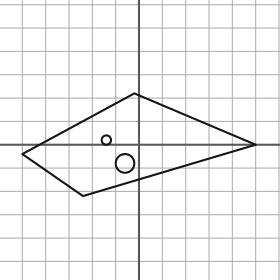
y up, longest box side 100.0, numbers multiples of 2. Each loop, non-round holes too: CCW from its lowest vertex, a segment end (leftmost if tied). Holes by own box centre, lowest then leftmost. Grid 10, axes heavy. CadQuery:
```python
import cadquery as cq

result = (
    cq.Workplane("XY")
    .moveTo(-24.0, -22.0)
    .lineTo(50.0, 0.0)
    .lineTo(-2.0, 22.0)
    .lineTo(-50.0, -4.0)
    .close()
    .moveTo(-6.0, -8.0)
    .circle(4.0)
    .moveTo(-14.0, 2.0)
    .circle(2.0)
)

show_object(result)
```